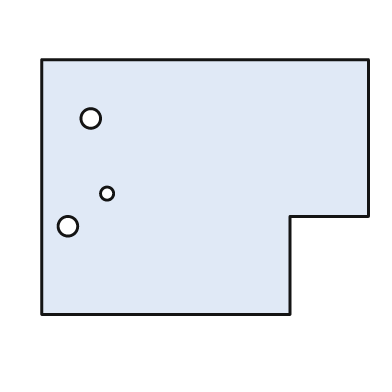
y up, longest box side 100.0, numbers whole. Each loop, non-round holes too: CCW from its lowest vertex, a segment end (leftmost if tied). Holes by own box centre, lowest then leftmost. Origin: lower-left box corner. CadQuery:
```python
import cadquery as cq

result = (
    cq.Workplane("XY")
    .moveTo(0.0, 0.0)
    .lineTo(76.0, 0.0)
    .lineTo(76.0, 30.0)
    .lineTo(100.0, 30.0)
    .lineTo(100.0, 78.0)
    .lineTo(0.0, 78.0)
    .close()
    .moveTo(8.0, 27.0)
    .circle(3.0)
    .moveTo(20.0, 37.0)
    .circle(2.0)
    .moveTo(15.0, 60.0)
    .circle(3.0)
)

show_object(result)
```